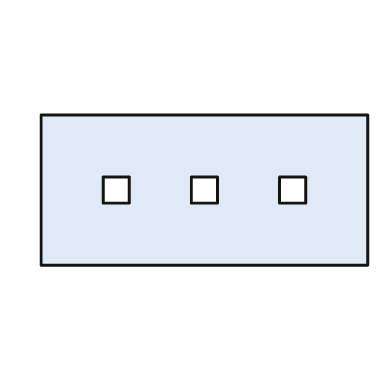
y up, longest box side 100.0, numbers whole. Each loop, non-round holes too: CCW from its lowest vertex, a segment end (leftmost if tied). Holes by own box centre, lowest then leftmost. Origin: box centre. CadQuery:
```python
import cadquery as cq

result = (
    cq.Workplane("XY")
    .moveTo(-50.0, -23.0)
    .lineTo(50.0, -23.0)
    .lineTo(50.0, 23.0)
    .lineTo(-50.0, 23.0)
    .close()
    .moveTo(-31.0, -4.0)
    .lineTo(-23.0, -4.0)
    .lineTo(-23.0, 4.0)
    .lineTo(-31.0, 4.0)
    .close()
    .moveTo(-4.0, -4.0)
    .lineTo(4.0, -4.0)
    .lineTo(4.0, 4.0)
    .lineTo(-4.0, 4.0)
    .close()
    .moveTo(23.0, -4.0)
    .lineTo(31.0, -4.0)
    .lineTo(31.0, 4.0)
    .lineTo(23.0, 4.0)
    .close()
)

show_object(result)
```